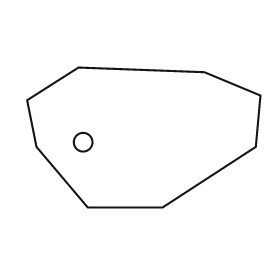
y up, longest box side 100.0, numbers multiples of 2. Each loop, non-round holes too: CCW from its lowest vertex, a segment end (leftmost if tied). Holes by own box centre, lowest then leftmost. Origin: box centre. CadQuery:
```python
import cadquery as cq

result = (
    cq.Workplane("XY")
    .moveTo(-24.0, -30.0)
    .lineTo(8.0, -30.0)
    .lineTo(48.0, -4.0)
    .lineTo(50.0, 18.0)
    .lineTo(26.0, 28.0)
    .lineTo(-28.0, 30.0)
    .lineTo(-50.0, 16.0)
    .lineTo(-46.0, -4.0)
    .close()
    .moveTo(-26.0, -2.0)
    .circle(4.0)
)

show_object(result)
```